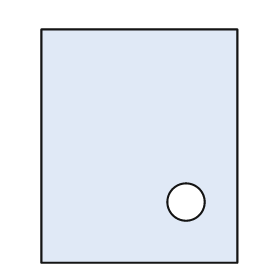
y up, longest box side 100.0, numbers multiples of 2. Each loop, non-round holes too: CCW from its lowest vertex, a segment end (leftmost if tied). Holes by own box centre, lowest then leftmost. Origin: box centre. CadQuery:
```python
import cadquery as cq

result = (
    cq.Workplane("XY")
    .moveTo(-42.0, -50.0)
    .lineTo(42.0, -50.0)
    .lineTo(42.0, 50.0)
    .lineTo(-42.0, 50.0)
    .close()
    .moveTo(20.0, -24.0)
    .circle(8.0)
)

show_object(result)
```